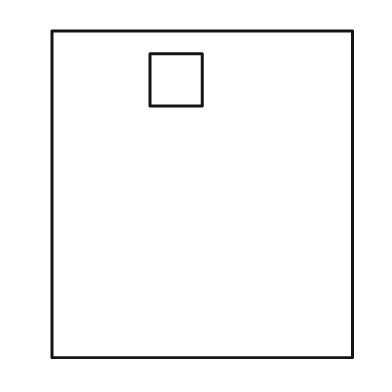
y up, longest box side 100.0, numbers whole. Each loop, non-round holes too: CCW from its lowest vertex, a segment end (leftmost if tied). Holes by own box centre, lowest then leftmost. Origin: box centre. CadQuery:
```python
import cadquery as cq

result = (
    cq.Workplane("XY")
    .moveTo(-46.0, -50.0)
    .lineTo(46.0, -50.0)
    .lineTo(46.0, 50.0)
    .lineTo(-46.0, 50.0)
    .close()
    .moveTo(-16.0, 27.0)
    .lineTo(0.0, 27.0)
    .lineTo(0.0, 43.0)
    .lineTo(-16.0, 43.0)
    .close()
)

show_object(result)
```